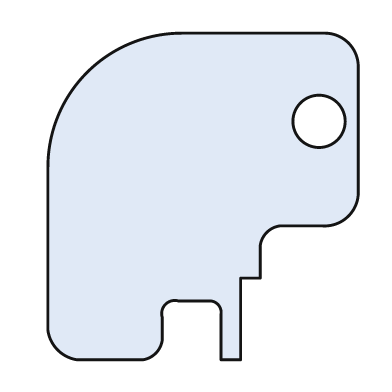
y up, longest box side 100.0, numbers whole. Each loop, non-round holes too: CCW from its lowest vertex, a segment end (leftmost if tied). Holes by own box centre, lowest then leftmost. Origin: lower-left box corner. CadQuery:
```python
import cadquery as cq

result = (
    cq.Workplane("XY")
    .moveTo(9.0, 0.0)
    .lineTo(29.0, 0.0)
    .threePointArc((33.0, 2.0), (35.0, 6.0))
    .lineTo(35.0, 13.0)
    .threePointArc((36.0, 17.0), (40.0, 18.0))
    .lineTo(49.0, 18.0)
    .threePointArc((52.0, 17.0), (53.0, 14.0))
    .lineTo(53.0, 0.0)
    .lineTo(59.0, 0.0)
    .lineTo(59.0, 25.0)
    .lineTo(65.0, 25.0)
    .lineTo(65.0, 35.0)
    .threePointArc((67.0, 39.0), (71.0, 41.0))
    .lineTo(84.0, 41.0)
    .threePointArc((92.0, 44.0), (95.0, 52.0))
    .lineTo(95.0, 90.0)
    .threePointArc((92.0, 97.0), (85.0, 100.0))
    .lineTo(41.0, 100.0)
    .threePointArc((12.0, 88.0), (0.0, 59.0))
    .lineTo(0.0, 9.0)
    .threePointArc((3.0, 3.0), (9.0, 0.0))
    .close()
    .moveTo(83.0, 73.0)
    .circle(8.0)
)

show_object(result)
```